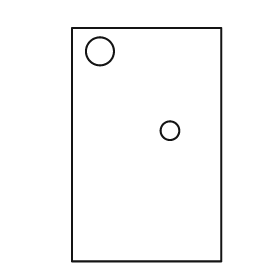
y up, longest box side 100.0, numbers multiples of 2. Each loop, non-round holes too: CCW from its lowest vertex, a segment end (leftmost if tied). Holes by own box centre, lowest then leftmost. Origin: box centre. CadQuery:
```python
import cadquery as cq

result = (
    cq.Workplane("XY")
    .moveTo(-32.0, -50.0)
    .lineTo(32.0, -50.0)
    .lineTo(32.0, 50.0)
    .lineTo(-32.0, 50.0)
    .close()
    .moveTo(10.0, 6.0)
    .circle(4.0)
    .moveTo(-20.0, 40.0)
    .circle(6.0)
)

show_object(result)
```